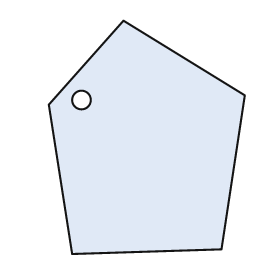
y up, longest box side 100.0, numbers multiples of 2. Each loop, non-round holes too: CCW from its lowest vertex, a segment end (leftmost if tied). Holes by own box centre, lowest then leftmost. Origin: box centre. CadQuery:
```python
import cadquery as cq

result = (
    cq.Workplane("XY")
    .moveTo(-32.0, -50.0)
    .lineTo(32.0, -48.0)
    .lineTo(42.0, 18.0)
    .lineTo(-10.0, 50.0)
    .lineTo(-42.0, 14.0)
    .close()
    .moveTo(-28.0, 16.0)
    .circle(4.0)
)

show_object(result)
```